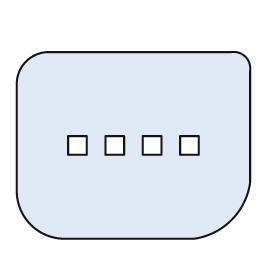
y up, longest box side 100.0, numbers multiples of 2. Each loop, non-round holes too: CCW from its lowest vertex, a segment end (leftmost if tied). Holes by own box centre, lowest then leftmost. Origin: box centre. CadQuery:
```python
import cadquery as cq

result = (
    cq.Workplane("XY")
    .moveTo(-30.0, -40.0)
    .lineTo(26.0, -40.0)
    .threePointArc((42.0, -32.0), (50.0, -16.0))
    .lineTo(50.0, 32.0)
    .threePointArc((48.0, 38.0), (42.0, 40.0))
    .lineTo(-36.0, 40.0)
    .threePointArc((-46.0, 36.0), (-50.0, 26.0))
    .lineTo(-50.0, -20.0)
    .threePointArc((-44.0, -34.0), (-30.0, -40.0))
    .close()
    .moveTo(-28.0, -4.0)
    .lineTo(-20.0, -4.0)
    .lineTo(-20.0, 4.0)
    .lineTo(-28.0, 4.0)
    .close()
    .moveTo(-12.0, -4.0)
    .lineTo(-4.0, -4.0)
    .lineTo(-4.0, 4.0)
    .lineTo(-12.0, 4.0)
    .close()
    .moveTo(4.0, -4.0)
    .lineTo(12.0, -4.0)
    .lineTo(12.0, 4.0)
    .lineTo(4.0, 4.0)
    .close()
    .moveTo(20.0, -4.0)
    .lineTo(28.0, -4.0)
    .lineTo(28.0, 4.0)
    .lineTo(20.0, 4.0)
    .close()
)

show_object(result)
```